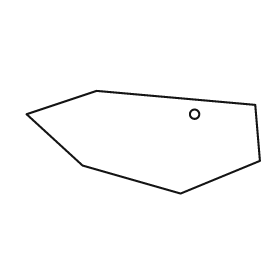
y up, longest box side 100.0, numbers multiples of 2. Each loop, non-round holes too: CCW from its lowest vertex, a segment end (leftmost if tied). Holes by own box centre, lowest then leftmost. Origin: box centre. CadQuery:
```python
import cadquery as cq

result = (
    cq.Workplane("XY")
    .moveTo(16.0, -22.0)
    .lineTo(50.0, -8.0)
    .lineTo(48.0, 16.0)
    .lineTo(-20.0, 22.0)
    .lineTo(-50.0, 12.0)
    .lineTo(-26.0, -10.0)
    .close()
    .moveTo(22.0, 12.0)
    .circle(2.0)
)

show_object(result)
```